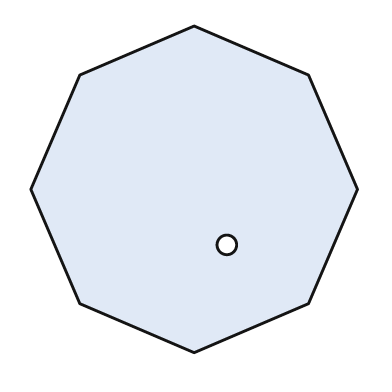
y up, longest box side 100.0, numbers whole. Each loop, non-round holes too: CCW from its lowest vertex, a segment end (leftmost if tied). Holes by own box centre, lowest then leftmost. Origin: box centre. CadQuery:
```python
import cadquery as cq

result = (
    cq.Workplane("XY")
    .moveTo(0.0, -50.0)
    .lineTo(35.0, -35.0)
    .lineTo(50.0, 0.0)
    .lineTo(35.0, 35.0)
    .lineTo(0.0, 50.0)
    .lineTo(-35.0, 35.0)
    .lineTo(-50.0, 0.0)
    .lineTo(-35.0, -35.0)
    .close()
    .moveTo(10.0, -17.0)
    .circle(3.0)
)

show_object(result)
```